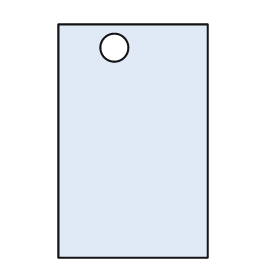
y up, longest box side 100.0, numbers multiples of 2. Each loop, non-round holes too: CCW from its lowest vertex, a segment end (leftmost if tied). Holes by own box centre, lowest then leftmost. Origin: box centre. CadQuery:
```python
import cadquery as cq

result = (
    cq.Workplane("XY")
    .moveTo(-32.0, -50.0)
    .lineTo(32.0, -50.0)
    .lineTo(32.0, 50.0)
    .lineTo(-32.0, 50.0)
    .close()
    .moveTo(-8.0, 40.0)
    .circle(6.0)
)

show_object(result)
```